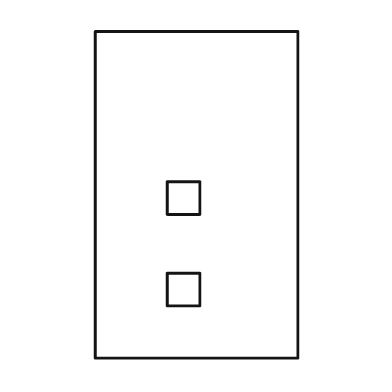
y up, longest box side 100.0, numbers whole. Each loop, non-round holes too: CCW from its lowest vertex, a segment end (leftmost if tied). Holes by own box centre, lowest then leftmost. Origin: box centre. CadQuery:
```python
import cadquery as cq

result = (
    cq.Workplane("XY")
    .moveTo(-31.0, -50.0)
    .lineTo(31.0, -50.0)
    .lineTo(31.0, 50.0)
    .lineTo(-31.0, 50.0)
    .close()
    .moveTo(-9.0, -34.0)
    .lineTo(1.0, -34.0)
    .lineTo(1.0, -24.0)
    .lineTo(-9.0, -24.0)
    .close()
    .moveTo(-9.0, -6.0)
    .lineTo(1.0, -6.0)
    .lineTo(1.0, 4.0)
    .lineTo(-9.0, 4.0)
    .close()
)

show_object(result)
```